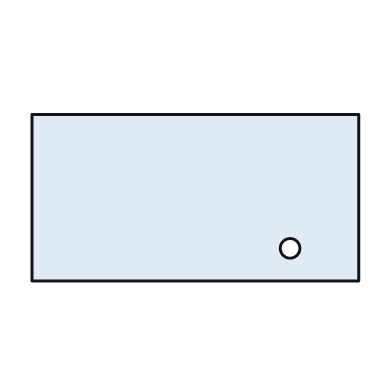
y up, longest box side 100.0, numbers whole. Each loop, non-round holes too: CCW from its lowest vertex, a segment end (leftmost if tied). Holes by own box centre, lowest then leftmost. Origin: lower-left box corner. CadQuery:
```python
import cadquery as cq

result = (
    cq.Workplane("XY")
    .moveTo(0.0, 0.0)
    .lineTo(100.0, 0.0)
    .lineTo(100.0, 51.0)
    .lineTo(0.0, 51.0)
    .close()
    .moveTo(79.0, 10.0)
    .circle(3.0)
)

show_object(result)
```